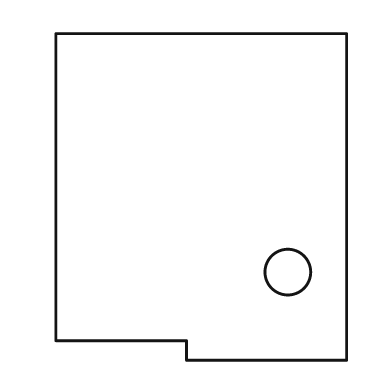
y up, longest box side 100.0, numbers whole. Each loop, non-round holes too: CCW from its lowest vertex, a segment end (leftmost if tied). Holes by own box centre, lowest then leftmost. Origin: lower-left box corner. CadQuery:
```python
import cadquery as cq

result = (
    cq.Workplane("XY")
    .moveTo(40.0, 0.0)
    .lineTo(89.0, 0.0)
    .lineTo(89.0, 100.0)
    .lineTo(0.0, 100.0)
    .lineTo(0.0, 6.0)
    .lineTo(40.0, 6.0)
    .close()
    .moveTo(71.0, 27.0)
    .circle(7.0)
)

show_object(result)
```